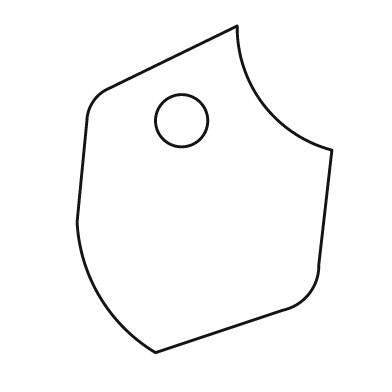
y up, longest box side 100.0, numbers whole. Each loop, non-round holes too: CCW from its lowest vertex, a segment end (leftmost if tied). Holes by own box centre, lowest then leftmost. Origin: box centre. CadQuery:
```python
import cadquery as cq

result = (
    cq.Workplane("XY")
    .moveTo(-15.0, -50.0)
    .lineTo(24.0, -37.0)
    .threePointArc((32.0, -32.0), (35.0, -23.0))
    .lineTo(39.0, 12.0)
    .threePointArc((18.0, 26.0), (10.0, 50.0))
    .lineTo(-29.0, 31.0)
    .threePointArc((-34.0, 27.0), (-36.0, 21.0))
    .lineTo(-39.0, -10.0)
    .threePointArc((-32.0, -33.0), (-15.0, -50.0))
    .close()
    .moveTo(-7.0, 21.0)
    .circle(8.0)
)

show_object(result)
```